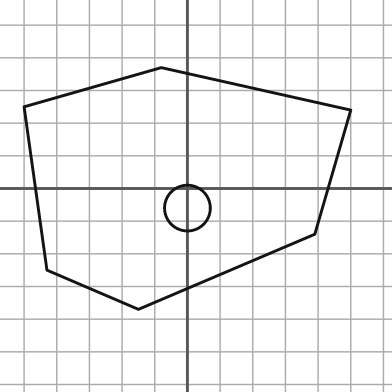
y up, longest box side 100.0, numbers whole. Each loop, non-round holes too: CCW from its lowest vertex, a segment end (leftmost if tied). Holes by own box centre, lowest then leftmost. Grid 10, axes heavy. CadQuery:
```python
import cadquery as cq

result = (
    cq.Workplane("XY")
    .moveTo(-15.0, -37.0)
    .lineTo(39.0, -14.0)
    .lineTo(50.0, 24.0)
    .lineTo(-8.0, 37.0)
    .lineTo(-50.0, 25.0)
    .lineTo(-43.0, -25.0)
    .close()
    .moveTo(0.0, -6.0)
    .circle(7.0)
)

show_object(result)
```